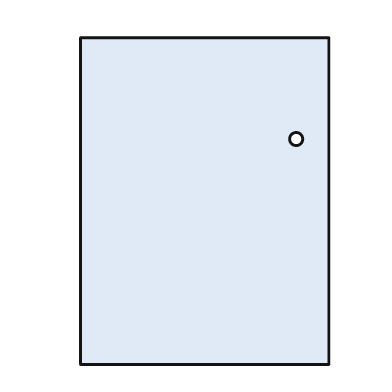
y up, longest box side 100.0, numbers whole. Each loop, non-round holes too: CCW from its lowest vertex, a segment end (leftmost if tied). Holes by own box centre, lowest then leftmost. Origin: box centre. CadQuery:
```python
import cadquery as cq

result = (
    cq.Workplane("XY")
    .moveTo(-38.0, -50.0)
    .lineTo(38.0, -50.0)
    .lineTo(38.0, 50.0)
    .lineTo(-38.0, 50.0)
    .close()
    .moveTo(28.0, 19.0)
    .circle(2.0)
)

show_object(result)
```